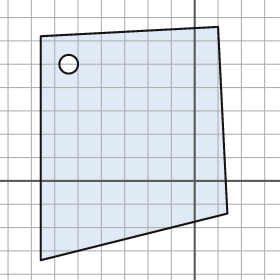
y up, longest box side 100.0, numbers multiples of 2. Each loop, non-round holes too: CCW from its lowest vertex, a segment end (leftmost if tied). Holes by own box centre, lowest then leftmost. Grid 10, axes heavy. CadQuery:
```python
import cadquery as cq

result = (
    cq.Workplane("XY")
    .moveTo(-66.0, -34.0)
    .lineTo(14.0, -14.0)
    .lineTo(10.0, 66.0)
    .lineTo(-66.0, 62.0)
    .close()
    .moveTo(-54.0, 50.0)
    .circle(4.0)
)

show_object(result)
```